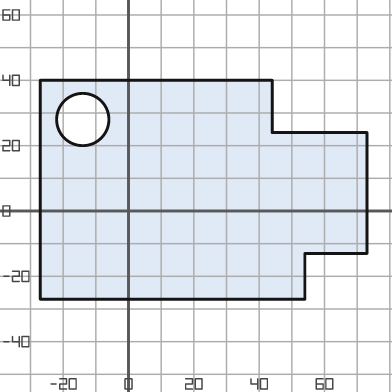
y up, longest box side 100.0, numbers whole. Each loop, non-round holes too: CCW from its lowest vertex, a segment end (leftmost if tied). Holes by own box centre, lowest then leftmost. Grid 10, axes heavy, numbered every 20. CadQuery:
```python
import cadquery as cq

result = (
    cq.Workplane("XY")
    .moveTo(-27.0, -27.0)
    .lineTo(54.0, -27.0)
    .lineTo(54.0, -13.0)
    .lineTo(73.0, -13.0)
    .lineTo(73.0, 24.0)
    .lineTo(44.0, 24.0)
    .lineTo(44.0, 40.0)
    .lineTo(-27.0, 40.0)
    .close()
    .moveTo(-14.0, 28.0)
    .circle(8.0)
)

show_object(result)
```